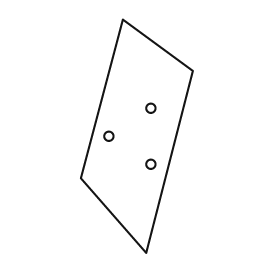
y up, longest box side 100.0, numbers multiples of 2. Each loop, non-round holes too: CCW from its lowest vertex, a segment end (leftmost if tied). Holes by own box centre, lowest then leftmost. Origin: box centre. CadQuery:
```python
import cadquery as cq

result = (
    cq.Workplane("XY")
    .moveTo(4.0, -50.0)
    .lineTo(24.0, 28.0)
    .lineTo(-6.0, 50.0)
    .lineTo(-24.0, -18.0)
    .close()
    .moveTo(6.0, -12.0)
    .circle(2.0)
    .moveTo(-12.0, 0.0)
    .circle(2.0)
    .moveTo(6.0, 12.0)
    .circle(2.0)
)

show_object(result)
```